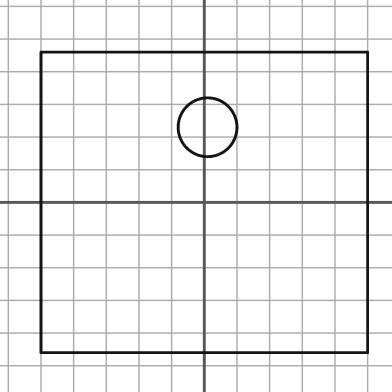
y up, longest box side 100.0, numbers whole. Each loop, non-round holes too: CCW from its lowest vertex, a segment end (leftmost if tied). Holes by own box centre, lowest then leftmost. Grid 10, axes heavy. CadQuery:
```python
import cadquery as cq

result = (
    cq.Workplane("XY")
    .moveTo(-50.0, -46.0)
    .lineTo(50.0, -46.0)
    .lineTo(50.0, 46.0)
    .lineTo(-50.0, 46.0)
    .close()
    .moveTo(1.0, 23.0)
    .circle(9.0)
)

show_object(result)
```